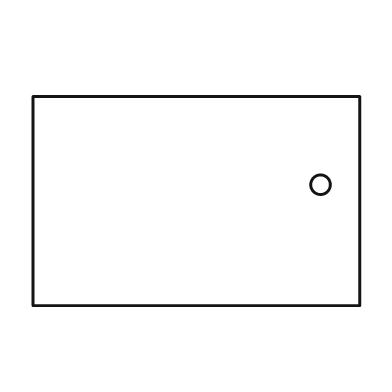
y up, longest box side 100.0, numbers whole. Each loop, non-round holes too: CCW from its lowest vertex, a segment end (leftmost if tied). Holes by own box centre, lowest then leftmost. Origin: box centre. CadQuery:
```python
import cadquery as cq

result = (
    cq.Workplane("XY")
    .moveTo(-50.0, -32.0)
    .lineTo(50.0, -32.0)
    .lineTo(50.0, 32.0)
    .lineTo(-50.0, 32.0)
    .close()
    .moveTo(38.0, 5.0)
    .circle(3.0)
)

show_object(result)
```